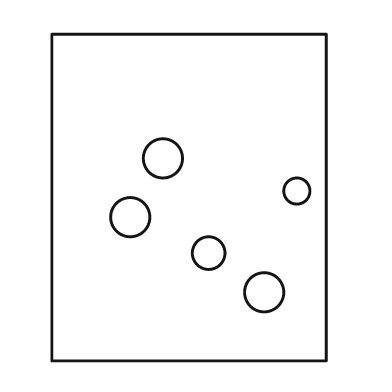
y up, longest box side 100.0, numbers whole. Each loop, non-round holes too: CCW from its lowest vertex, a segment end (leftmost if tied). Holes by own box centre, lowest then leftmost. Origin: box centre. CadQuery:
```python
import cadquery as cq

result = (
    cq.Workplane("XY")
    .moveTo(-42.0, -50.0)
    .lineTo(42.0, -50.0)
    .lineTo(42.0, 50.0)
    .lineTo(-42.0, 50.0)
    .close()
    .moveTo(23.0, -29.0)
    .circle(6.0)
    .moveTo(6.0, -17.0)
    .circle(5.0)
    .moveTo(-18.0, -6.0)
    .circle(6.0)
    .moveTo(33.0, 2.0)
    .circle(4.0)
    .moveTo(-8.0, 12.0)
    .circle(6.0)
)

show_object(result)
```